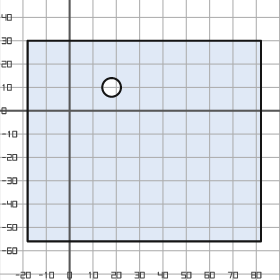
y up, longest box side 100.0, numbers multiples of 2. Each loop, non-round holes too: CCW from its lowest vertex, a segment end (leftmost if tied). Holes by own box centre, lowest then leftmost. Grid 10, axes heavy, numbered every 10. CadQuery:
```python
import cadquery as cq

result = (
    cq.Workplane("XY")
    .moveTo(-18.0, -56.0)
    .lineTo(82.0, -56.0)
    .lineTo(82.0, 30.0)
    .lineTo(-18.0, 30.0)
    .close()
    .moveTo(18.0, 10.0)
    .circle(4.0)
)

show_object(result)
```